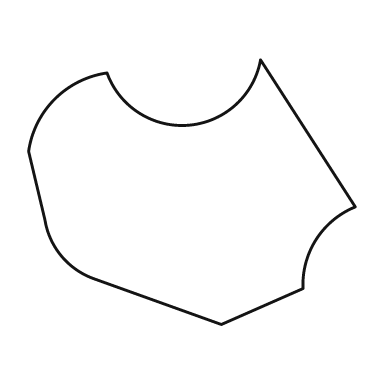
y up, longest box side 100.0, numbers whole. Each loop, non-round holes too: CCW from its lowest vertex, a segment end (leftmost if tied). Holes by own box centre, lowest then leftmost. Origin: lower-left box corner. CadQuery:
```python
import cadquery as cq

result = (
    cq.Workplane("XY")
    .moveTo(59.0, 0.0)
    .lineTo(84.0, 11.0)
    .threePointArc((88.0, 26.0), (100.0, 36.0))
    .lineTo(71.0, 81.0)
    .threePointArc((49.0, 61.0), (24.0, 77.0))
    .threePointArc((8.0, 69.0), (0.0, 53.0))
    .lineTo(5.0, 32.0)
    .threePointArc((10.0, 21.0), (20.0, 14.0))
    .close()
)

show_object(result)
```